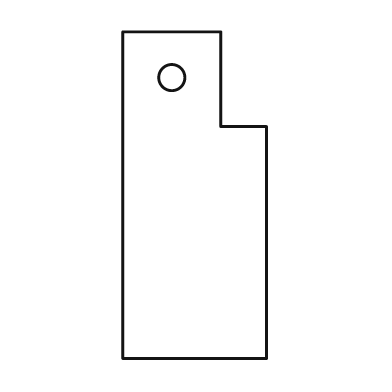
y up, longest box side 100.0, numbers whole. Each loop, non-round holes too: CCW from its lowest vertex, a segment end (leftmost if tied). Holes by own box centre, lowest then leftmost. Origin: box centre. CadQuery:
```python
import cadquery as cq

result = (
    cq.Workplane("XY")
    .moveTo(-22.0, -50.0)
    .lineTo(22.0, -50.0)
    .lineTo(22.0, 21.0)
    .lineTo(8.0, 21.0)
    .lineTo(8.0, 50.0)
    .lineTo(-22.0, 50.0)
    .close()
    .moveTo(-7.0, 36.0)
    .circle(4.0)
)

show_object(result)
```